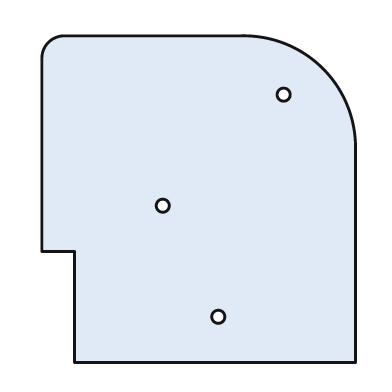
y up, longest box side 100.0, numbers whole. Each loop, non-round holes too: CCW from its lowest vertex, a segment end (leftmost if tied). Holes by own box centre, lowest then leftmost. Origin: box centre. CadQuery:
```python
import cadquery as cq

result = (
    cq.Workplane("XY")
    .moveTo(-38.0, -50.0)
    .lineTo(48.0, -50.0)
    .lineTo(48.0, 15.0)
    .threePointArc((38.0, 40.0), (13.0, 50.0))
    .lineTo(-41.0, 50.0)
    .threePointArc((-46.0, 48.0), (-48.0, 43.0))
    .lineTo(-48.0, -16.0)
    .lineTo(-38.0, -16.0)
    .close()
    .moveTo(6.0, -36.0)
    .circle(2.0)
    .moveTo(-11.0, -2.0)
    .circle(2.0)
    .moveTo(26.0, 32.0)
    .circle(2.0)
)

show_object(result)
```